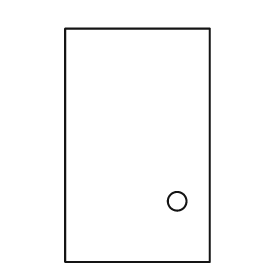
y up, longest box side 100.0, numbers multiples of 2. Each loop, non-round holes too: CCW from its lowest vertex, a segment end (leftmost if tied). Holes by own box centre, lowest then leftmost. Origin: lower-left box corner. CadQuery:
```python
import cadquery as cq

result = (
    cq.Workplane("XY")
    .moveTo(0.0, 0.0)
    .lineTo(62.0, 0.0)
    .lineTo(62.0, 100.0)
    .lineTo(0.0, 100.0)
    .close()
    .moveTo(48.0, 26.0)
    .circle(4.0)
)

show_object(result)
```